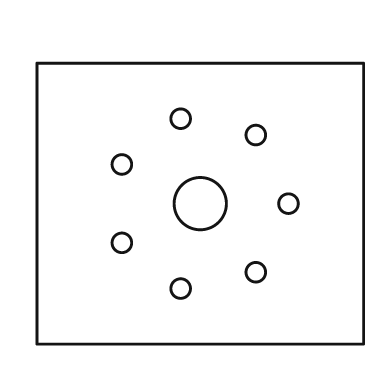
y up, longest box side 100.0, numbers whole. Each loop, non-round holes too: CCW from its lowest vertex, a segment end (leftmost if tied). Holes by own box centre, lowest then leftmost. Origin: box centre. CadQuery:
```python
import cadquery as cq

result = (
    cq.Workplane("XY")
    .moveTo(-50.0, -43.0)
    .lineTo(50.0, -43.0)
    .lineTo(50.0, 43.0)
    .lineTo(-50.0, 43.0)
    .close()
    .moveTo(-6.0, -26.0)
    .circle(3.0)
    .moveTo(17.0, -21.0)
    .circle(3.0)
    .moveTo(-24.0, -12.0)
    .circle(3.0)
    .moveTo(0.0, 0.0)
    .circle(8.0)
    .moveTo(27.0, 0.0)
    .circle(3.0)
    .moveTo(-24.0, 12.0)
    .circle(3.0)
    .moveTo(17.0, 21.0)
    .circle(3.0)
    .moveTo(-6.0, 26.0)
    .circle(3.0)
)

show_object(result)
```